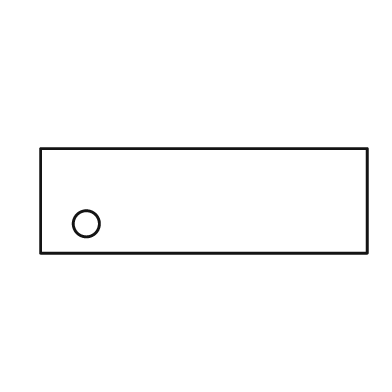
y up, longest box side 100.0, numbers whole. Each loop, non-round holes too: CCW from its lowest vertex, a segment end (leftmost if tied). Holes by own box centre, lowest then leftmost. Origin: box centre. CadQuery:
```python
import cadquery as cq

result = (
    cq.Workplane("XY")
    .moveTo(-50.0, -16.0)
    .lineTo(50.0, -16.0)
    .lineTo(50.0, 16.0)
    .lineTo(-50.0, 16.0)
    .close()
    .moveTo(-36.0, -7.0)
    .circle(4.0)
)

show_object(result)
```